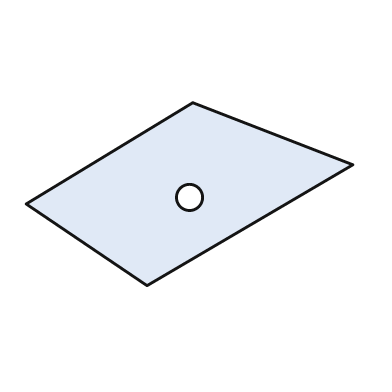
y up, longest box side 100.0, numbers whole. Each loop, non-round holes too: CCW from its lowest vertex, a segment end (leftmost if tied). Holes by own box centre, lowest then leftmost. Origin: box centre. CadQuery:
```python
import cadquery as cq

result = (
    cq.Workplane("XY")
    .moveTo(-13.0, -28.0)
    .lineTo(50.0, 9.0)
    .lineTo(1.0, 28.0)
    .lineTo(-50.0, -3.0)
    .close()
    .moveTo(0.0, -1.0)
    .circle(4.0)
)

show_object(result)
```